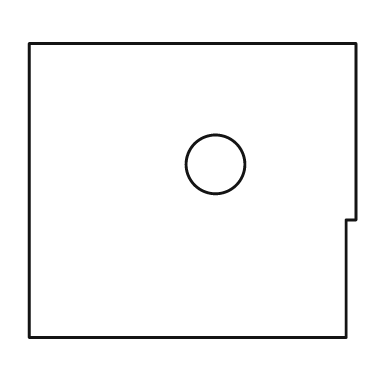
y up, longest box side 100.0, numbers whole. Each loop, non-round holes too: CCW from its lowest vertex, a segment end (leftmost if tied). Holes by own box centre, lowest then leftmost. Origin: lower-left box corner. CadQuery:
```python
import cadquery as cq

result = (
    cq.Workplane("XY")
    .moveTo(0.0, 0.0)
    .lineTo(97.0, 0.0)
    .lineTo(97.0, 36.0)
    .lineTo(100.0, 36.0)
    .lineTo(100.0, 90.0)
    .lineTo(0.0, 90.0)
    .close()
    .moveTo(57.0, 53.0)
    .circle(9.0)
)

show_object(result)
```